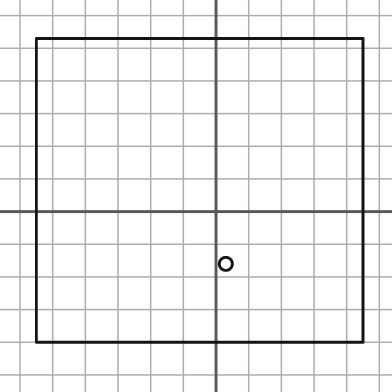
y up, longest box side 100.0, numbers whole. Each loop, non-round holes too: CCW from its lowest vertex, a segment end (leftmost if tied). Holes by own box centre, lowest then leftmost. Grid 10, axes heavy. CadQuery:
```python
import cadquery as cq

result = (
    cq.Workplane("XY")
    .moveTo(-55.0, -40.0)
    .lineTo(45.0, -40.0)
    .lineTo(45.0, 53.0)
    .lineTo(-55.0, 53.0)
    .close()
    .moveTo(3.0, -16.0)
    .circle(2.0)
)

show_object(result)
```